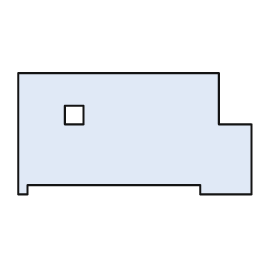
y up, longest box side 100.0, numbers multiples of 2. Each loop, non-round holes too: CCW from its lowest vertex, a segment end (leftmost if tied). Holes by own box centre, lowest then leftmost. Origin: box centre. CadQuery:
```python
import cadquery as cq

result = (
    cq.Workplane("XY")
    .moveTo(-50.0, -26.0)
    .lineTo(-46.0, -26.0)
    .lineTo(-46.0, -22.0)
    .lineTo(28.0, -22.0)
    .lineTo(28.0, -26.0)
    .lineTo(50.0, -26.0)
    .lineTo(50.0, 4.0)
    .lineTo(36.0, 4.0)
    .lineTo(36.0, 26.0)
    .lineTo(-50.0, 26.0)
    .close()
    .moveTo(-30.0, 4.0)
    .lineTo(-22.0, 4.0)
    .lineTo(-22.0, 12.0)
    .lineTo(-30.0, 12.0)
    .close()
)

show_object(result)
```